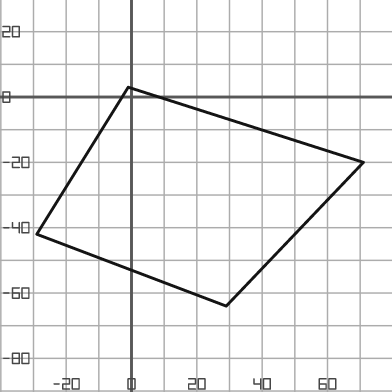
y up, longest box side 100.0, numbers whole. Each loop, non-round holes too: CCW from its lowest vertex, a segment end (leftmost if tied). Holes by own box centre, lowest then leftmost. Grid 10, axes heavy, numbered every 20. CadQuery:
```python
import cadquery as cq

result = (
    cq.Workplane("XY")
    .moveTo(29.0, -64.0)
    .lineTo(71.0, -20.0)
    .lineTo(-1.0, 3.0)
    .lineTo(-29.0, -42.0)
    .close()
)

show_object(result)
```